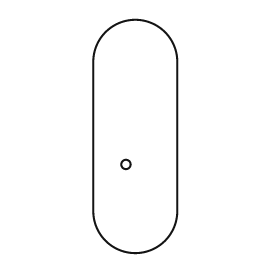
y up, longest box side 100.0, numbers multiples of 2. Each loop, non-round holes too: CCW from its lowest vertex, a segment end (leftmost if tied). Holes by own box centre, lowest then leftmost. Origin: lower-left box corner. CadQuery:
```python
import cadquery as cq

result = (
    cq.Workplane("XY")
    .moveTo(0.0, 18.0)
    .threePointArc((18.0, 0.0), (36.0, 18.0))
    .lineTo(36.0, 82.0)
    .threePointArc((18.0, 100.0), (0.0, 82.0))
    .close()
    .moveTo(14.0, 38.0)
    .circle(2.0)
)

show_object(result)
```